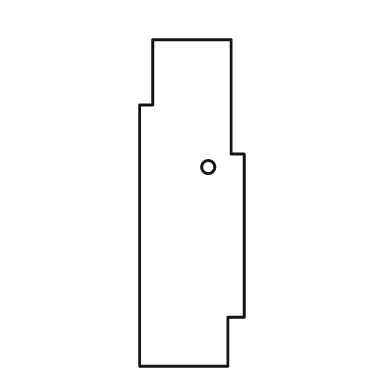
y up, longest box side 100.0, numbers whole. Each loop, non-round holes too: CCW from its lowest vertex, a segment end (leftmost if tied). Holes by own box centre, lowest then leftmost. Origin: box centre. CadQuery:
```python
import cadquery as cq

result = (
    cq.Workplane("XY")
    .moveTo(-16.0, -50.0)
    .lineTo(11.0, -50.0)
    .lineTo(11.0, -35.0)
    .lineTo(16.0, -35.0)
    .lineTo(16.0, 15.0)
    .lineTo(12.0, 15.0)
    .lineTo(12.0, 50.0)
    .lineTo(-12.0, 50.0)
    .lineTo(-12.0, 30.0)
    .lineTo(-16.0, 30.0)
    .close()
    .moveTo(5.0, 11.0)
    .circle(2.0)
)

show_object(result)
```